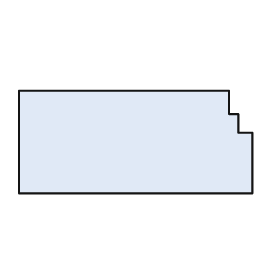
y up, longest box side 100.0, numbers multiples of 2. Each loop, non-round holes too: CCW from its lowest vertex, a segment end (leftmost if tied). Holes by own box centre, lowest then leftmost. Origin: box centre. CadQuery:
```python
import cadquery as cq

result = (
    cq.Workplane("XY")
    .moveTo(-50.0, -22.0)
    .lineTo(50.0, -22.0)
    .lineTo(50.0, 4.0)
    .lineTo(44.0, 4.0)
    .lineTo(44.0, 12.0)
    .lineTo(40.0, 12.0)
    .lineTo(40.0, 22.0)
    .lineTo(-50.0, 22.0)
    .close()
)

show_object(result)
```